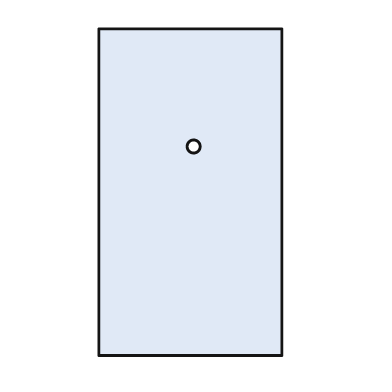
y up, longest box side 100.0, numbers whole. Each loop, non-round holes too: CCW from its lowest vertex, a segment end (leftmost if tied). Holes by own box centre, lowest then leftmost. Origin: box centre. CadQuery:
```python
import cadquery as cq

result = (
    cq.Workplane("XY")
    .moveTo(-28.0, -50.0)
    .lineTo(28.0, -50.0)
    .lineTo(28.0, 50.0)
    .lineTo(-28.0, 50.0)
    .close()
    .moveTo(1.0, 14.0)
    .circle(2.0)
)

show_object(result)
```